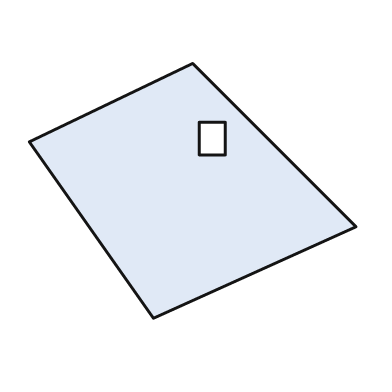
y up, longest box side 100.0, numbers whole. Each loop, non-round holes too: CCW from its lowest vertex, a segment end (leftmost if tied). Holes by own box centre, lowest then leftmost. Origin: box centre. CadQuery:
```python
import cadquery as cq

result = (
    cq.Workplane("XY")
    .moveTo(-12.0, -39.0)
    .lineTo(50.0, -11.0)
    .lineTo(0.0, 39.0)
    .lineTo(-50.0, 15.0)
    .close()
    .moveTo(2.0, 11.0)
    .lineTo(10.0, 11.0)
    .lineTo(10.0, 21.0)
    .lineTo(2.0, 21.0)
    .close()
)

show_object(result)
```